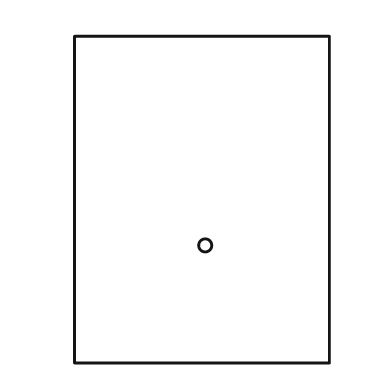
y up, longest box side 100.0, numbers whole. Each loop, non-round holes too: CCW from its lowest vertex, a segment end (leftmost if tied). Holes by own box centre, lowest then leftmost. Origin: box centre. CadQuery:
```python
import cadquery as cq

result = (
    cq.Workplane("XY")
    .moveTo(-39.0, -50.0)
    .lineTo(39.0, -50.0)
    .lineTo(39.0, 50.0)
    .lineTo(-39.0, 50.0)
    .close()
    .moveTo(1.0, -14.0)
    .circle(2.0)
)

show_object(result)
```